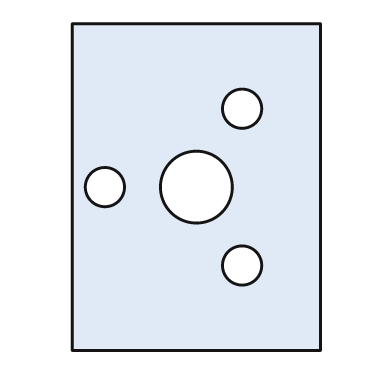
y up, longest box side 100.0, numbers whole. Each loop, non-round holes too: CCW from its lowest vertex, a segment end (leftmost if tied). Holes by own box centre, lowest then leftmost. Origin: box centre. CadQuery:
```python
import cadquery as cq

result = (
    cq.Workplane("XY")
    .moveTo(-38.0, -50.0)
    .lineTo(38.0, -50.0)
    .lineTo(38.0, 50.0)
    .lineTo(-38.0, 50.0)
    .close()
    .moveTo(14.0, -24.0)
    .circle(6.0)
    .moveTo(-28.0, 0.0)
    .circle(6.0)
    .moveTo(0.0, 0.0)
    .circle(11.0)
    .moveTo(14.0, 24.0)
    .circle(6.0)
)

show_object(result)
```